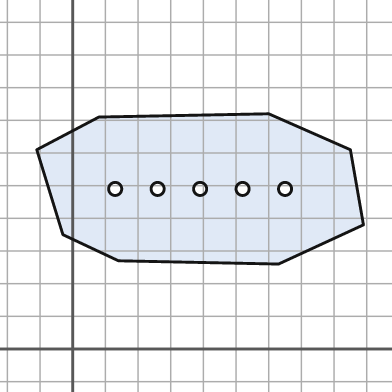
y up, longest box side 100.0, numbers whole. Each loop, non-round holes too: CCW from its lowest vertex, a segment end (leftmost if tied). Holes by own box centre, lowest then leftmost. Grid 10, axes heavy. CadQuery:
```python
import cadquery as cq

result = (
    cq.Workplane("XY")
    .moveTo(63.0, 26.0)
    .lineTo(89.0, 38.0)
    .lineTo(85.0, 61.0)
    .lineTo(60.0, 72.0)
    .lineTo(8.0, 71.0)
    .lineTo(-11.0, 61.0)
    .lineTo(-3.0, 35.0)
    .lineTo(14.0, 27.0)
    .close()
    .moveTo(13.0, 49.0)
    .circle(2.0)
    .moveTo(26.0, 49.0)
    .circle(2.0)
    .moveTo(39.0, 49.0)
    .circle(2.0)
    .moveTo(52.0, 49.0)
    .circle(2.0)
    .moveTo(65.0, 49.0)
    .circle(2.0)
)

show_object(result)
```